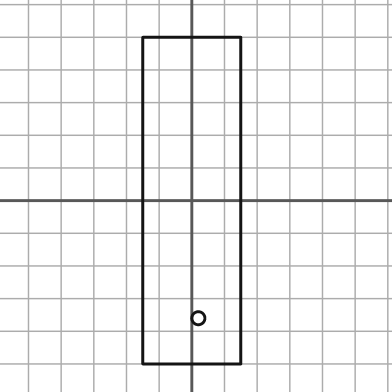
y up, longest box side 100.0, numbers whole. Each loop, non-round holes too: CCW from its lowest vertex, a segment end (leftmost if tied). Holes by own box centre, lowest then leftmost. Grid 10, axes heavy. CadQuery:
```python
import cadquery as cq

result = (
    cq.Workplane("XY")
    .moveTo(-15.0, -50.0)
    .lineTo(15.0, -50.0)
    .lineTo(15.0, 50.0)
    .lineTo(-15.0, 50.0)
    .close()
    .moveTo(2.0, -36.0)
    .circle(2.0)
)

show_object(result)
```